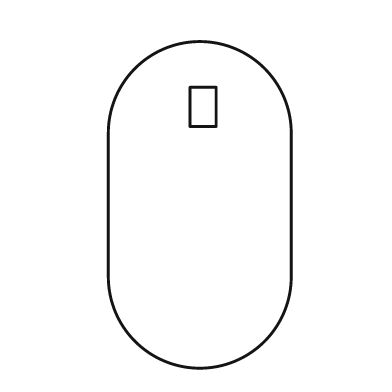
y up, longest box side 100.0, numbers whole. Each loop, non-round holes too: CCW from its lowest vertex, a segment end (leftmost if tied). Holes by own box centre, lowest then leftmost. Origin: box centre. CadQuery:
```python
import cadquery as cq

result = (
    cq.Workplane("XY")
    .moveTo(-28.0, -22.0)
    .threePointArc((0.0, -50.0), (28.0, -22.0))
    .lineTo(28.0, 22.0)
    .threePointArc((0.0, 50.0), (-28.0, 22.0))
    .close()
    .moveTo(-3.0, 24.0)
    .lineTo(5.0, 24.0)
    .lineTo(5.0, 36.0)
    .lineTo(-3.0, 36.0)
    .close()
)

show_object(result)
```